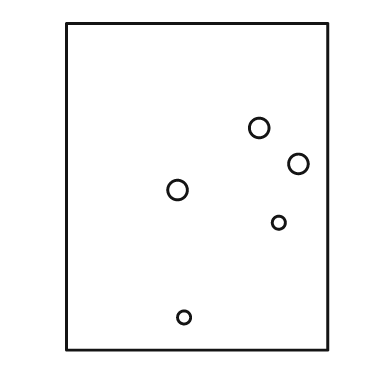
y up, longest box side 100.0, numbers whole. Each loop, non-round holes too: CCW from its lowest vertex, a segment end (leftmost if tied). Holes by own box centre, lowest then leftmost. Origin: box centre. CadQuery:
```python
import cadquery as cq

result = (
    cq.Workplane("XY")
    .moveTo(-40.0, -50.0)
    .lineTo(40.0, -50.0)
    .lineTo(40.0, 50.0)
    .lineTo(-40.0, 50.0)
    .close()
    .moveTo(-4.0, -40.0)
    .circle(2.0)
    .moveTo(25.0, -11.0)
    .circle(2.0)
    .moveTo(-6.0, -1.0)
    .circle(3.0)
    .moveTo(31.0, 7.0)
    .circle(3.0)
    .moveTo(19.0, 18.0)
    .circle(3.0)
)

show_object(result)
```